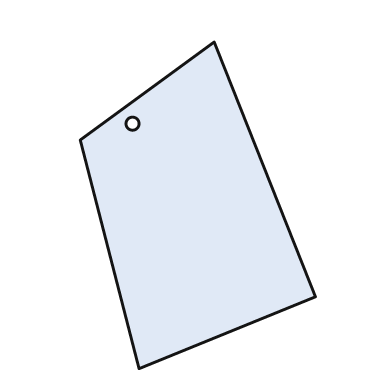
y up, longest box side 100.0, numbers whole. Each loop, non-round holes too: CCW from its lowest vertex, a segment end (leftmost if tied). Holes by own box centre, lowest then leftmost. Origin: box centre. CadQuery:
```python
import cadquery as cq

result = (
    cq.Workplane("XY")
    .moveTo(-18.0, -50.0)
    .lineTo(36.0, -28.0)
    .lineTo(5.0, 50.0)
    .lineTo(-36.0, 20.0)
    .close()
    .moveTo(-20.0, 25.0)
    .circle(2.0)
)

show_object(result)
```